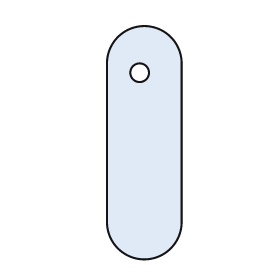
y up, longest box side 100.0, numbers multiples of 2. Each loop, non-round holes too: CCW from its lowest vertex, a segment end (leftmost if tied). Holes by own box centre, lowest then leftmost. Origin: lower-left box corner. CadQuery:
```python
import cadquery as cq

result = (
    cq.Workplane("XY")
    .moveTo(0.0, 16.0)
    .threePointArc((16.0, 0.0), (32.0, 16.0))
    .lineTo(32.0, 84.0)
    .threePointArc((16.0, 100.0), (0.0, 84.0))
    .close()
    .moveTo(14.0, 80.0)
    .circle(4.0)
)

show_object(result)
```